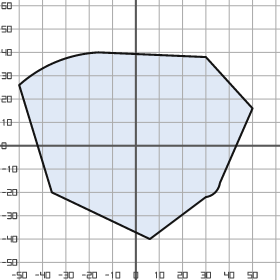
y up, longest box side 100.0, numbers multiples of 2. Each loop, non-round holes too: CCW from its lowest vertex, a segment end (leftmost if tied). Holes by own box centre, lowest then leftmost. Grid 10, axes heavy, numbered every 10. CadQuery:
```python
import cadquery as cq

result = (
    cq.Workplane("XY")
    .moveTo(6.0, -40.0)
    .lineTo(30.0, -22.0)
    .threePointArc((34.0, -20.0), (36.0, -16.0))
    .lineTo(50.0, 16.0)
    .lineTo(30.0, 38.0)
    .lineTo(-16.0, 40.0)
    .threePointArc((-34.0, 36.0), (-50.0, 26.0))
    .lineTo(-36.0, -20.0)
    .close()
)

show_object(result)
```